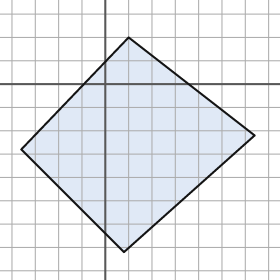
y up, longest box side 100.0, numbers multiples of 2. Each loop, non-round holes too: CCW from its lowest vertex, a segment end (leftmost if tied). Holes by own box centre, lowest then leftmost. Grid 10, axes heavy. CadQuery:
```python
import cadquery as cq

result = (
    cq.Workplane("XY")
    .moveTo(8.0, -72.0)
    .lineTo(64.0, -22.0)
    .lineTo(10.0, 20.0)
    .lineTo(-36.0, -28.0)
    .close()
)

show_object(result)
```